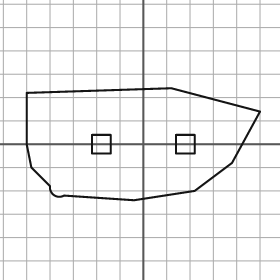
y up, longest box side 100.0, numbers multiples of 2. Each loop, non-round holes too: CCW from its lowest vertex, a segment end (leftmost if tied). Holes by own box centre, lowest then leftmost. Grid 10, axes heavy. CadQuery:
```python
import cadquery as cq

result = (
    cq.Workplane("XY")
    .moveTo(-4.0, -24.0)
    .lineTo(22.0, -20.0)
    .lineTo(38.0, -8.0)
    .lineTo(50.0, 14.0)
    .lineTo(12.0, 24.0)
    .lineTo(-50.0, 22.0)
    .lineTo(-50.0, 0.0)
    .lineTo(-48.0, -10.0)
    .lineTo(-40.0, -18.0)
    .threePointArc((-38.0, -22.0), (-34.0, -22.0))
    .close()
    .moveTo(-22.0, -4.0)
    .lineTo(-14.0, -4.0)
    .lineTo(-14.0, 4.0)
    .lineTo(-22.0, 4.0)
    .close()
    .moveTo(14.0, -4.0)
    .lineTo(22.0, -4.0)
    .lineTo(22.0, 4.0)
    .lineTo(14.0, 4.0)
    .close()
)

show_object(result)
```